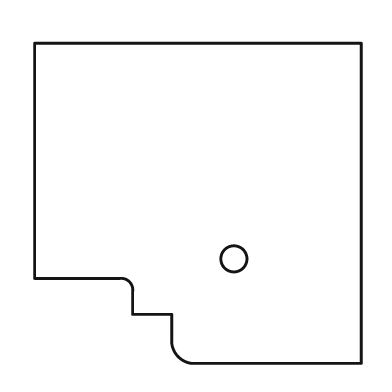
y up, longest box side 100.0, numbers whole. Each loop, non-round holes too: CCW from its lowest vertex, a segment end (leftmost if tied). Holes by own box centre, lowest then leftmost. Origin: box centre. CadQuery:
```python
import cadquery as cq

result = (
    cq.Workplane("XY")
    .moveTo(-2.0, -49.0)
    .lineTo(50.0, -49.0)
    .lineTo(50.0, 49.0)
    .lineTo(-50.0, 49.0)
    .lineTo(-50.0, -23.0)
    .lineTo(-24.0, -23.0)
    .threePointArc((-21.0, -24.0), (-20.0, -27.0))
    .lineTo(-20.0, -34.0)
    .lineTo(-8.0, -34.0)
    .lineTo(-8.0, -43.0)
    .threePointArc((-6.0, -47.0), (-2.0, -49.0))
    .close()
    .moveTo(11.0, -17.0)
    .circle(4.0)
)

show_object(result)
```